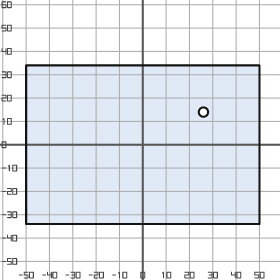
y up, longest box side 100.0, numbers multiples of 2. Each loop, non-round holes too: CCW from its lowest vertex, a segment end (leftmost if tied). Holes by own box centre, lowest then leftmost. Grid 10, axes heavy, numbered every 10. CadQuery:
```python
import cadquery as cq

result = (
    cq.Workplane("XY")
    .moveTo(-50.0, -34.0)
    .lineTo(50.0, -34.0)
    .lineTo(50.0, 34.0)
    .lineTo(-50.0, 34.0)
    .close()
    .moveTo(26.0, 14.0)
    .circle(2.0)
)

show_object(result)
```